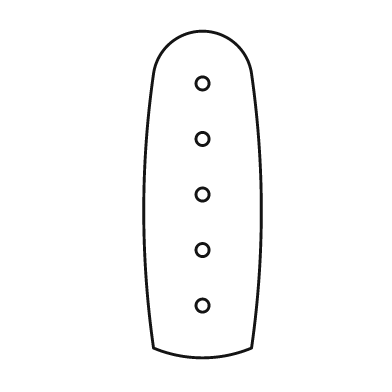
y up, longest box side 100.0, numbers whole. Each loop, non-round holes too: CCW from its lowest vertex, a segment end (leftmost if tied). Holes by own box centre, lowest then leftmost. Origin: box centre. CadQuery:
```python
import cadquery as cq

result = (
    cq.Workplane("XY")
    .moveTo(-15.0, -47.0)
    .threePointArc((0.0, -50.0), (15.0, -47.0))
    .threePointArc((18.0, -5.0), (15.0, 37.0))
    .threePointArc((0.0, 50.0), (-15.0, 37.0))
    .threePointArc((-18.0, -5.0), (-15.0, -47.0))
    .close()
    .moveTo(0.0, -34.0)
    .circle(2.0)
    .moveTo(0.0, -17.0)
    .circle(2.0)
    .moveTo(0.0, 0.0)
    .circle(2.0)
    .moveTo(0.0, 17.0)
    .circle(2.0)
    .moveTo(0.0, 34.0)
    .circle(2.0)
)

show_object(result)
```